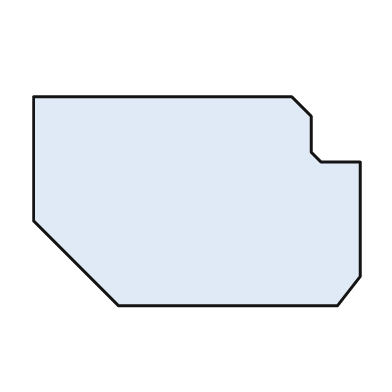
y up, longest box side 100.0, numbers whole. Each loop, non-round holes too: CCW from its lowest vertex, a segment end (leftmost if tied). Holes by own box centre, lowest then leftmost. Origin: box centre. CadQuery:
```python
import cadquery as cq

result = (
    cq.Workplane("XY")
    .moveTo(-24.0, -32.0)
    .lineTo(43.0, -32.0)
    .lineTo(50.0, -23.0)
    .lineTo(50.0, 12.0)
    .lineTo(38.0, 12.0)
    .lineTo(35.0, 15.0)
    .lineTo(35.0, 26.0)
    .lineTo(29.0, 32.0)
    .lineTo(-50.0, 32.0)
    .lineTo(-50.0, -6.0)
    .close()
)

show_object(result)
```